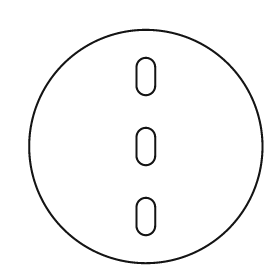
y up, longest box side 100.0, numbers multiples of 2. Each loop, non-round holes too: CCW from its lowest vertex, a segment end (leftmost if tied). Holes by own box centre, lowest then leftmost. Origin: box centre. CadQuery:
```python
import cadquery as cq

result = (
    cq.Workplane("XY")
    .moveTo(0.0, 0.0)
    .circle(50.0)
    .moveTo(-4.0, -34.0)
    .threePointArc((0.0, -38.0), (4.0, -34.0))
    .lineTo(4.0, -26.0)
    .threePointArc((0.0, -22.0), (-4.0, -26.0))
    .close()
    .moveTo(-4.0, -4.0)
    .threePointArc((0.0, -8.0), (4.0, -4.0))
    .lineTo(4.0, 4.0)
    .threePointArc((0.0, 8.0), (-4.0, 4.0))
    .close()
    .moveTo(-4.0, 26.0)
    .threePointArc((0.0, 22.0), (4.0, 26.0))
    .lineTo(4.0, 34.0)
    .threePointArc((0.0, 38.0), (-4.0, 34.0))
    .close()
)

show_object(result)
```